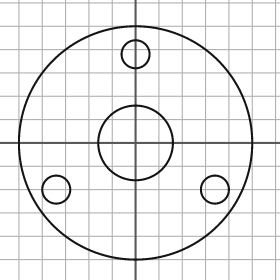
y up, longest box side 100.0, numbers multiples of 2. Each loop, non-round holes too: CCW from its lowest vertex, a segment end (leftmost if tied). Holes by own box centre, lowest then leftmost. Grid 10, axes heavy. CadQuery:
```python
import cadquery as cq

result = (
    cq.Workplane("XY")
    .moveTo(0.0, 0.0)
    .circle(50.0)
    .moveTo(-34.0, -20.0)
    .circle(6.0)
    .moveTo(34.0, -20.0)
    .circle(6.0)
    .moveTo(0.0, 0.0)
    .circle(16.0)
    .moveTo(0.0, 38.0)
    .circle(6.0)
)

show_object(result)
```